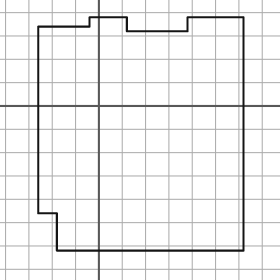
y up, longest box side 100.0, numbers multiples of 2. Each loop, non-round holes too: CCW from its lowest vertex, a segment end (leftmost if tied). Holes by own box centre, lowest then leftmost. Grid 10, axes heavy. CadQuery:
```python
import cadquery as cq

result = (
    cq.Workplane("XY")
    .moveTo(-18.0, -62.0)
    .lineTo(62.0, -62.0)
    .lineTo(62.0, 38.0)
    .lineTo(38.0, 38.0)
    .lineTo(38.0, 32.0)
    .lineTo(12.0, 32.0)
    .lineTo(12.0, 38.0)
    .lineTo(-4.0, 38.0)
    .lineTo(-4.0, 34.0)
    .lineTo(-26.0, 34.0)
    .lineTo(-26.0, -46.0)
    .lineTo(-18.0, -46.0)
    .close()
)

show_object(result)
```